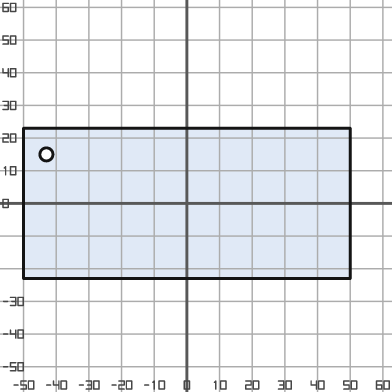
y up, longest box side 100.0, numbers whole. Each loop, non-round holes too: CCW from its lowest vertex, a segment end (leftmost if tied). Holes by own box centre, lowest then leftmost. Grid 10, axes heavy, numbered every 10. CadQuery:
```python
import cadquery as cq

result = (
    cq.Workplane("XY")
    .moveTo(-50.0, -23.0)
    .lineTo(50.0, -23.0)
    .lineTo(50.0, 23.0)
    .lineTo(-50.0, 23.0)
    .close()
    .moveTo(-43.0, 15.0)
    .circle(2.0)
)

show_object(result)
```